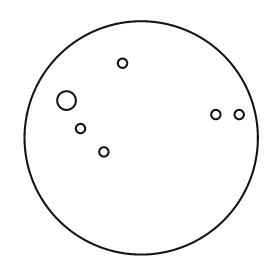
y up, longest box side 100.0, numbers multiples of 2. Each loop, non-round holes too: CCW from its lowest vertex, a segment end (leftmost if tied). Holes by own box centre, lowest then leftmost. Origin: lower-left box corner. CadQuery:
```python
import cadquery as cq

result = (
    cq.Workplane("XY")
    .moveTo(50.0, 50.0)
    .circle(50.0)
    .moveTo(34.0, 44.0)
    .circle(2.0)
    .moveTo(24.0, 54.0)
    .circle(2.0)
    .moveTo(82.0, 60.0)
    .circle(2.0)
    .moveTo(92.0, 60.0)
    .circle(2.0)
    .moveTo(18.0, 66.0)
    .circle(4.0)
    .moveTo(42.0, 82.0)
    .circle(2.0)
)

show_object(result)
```